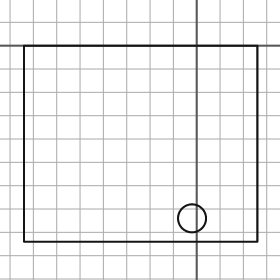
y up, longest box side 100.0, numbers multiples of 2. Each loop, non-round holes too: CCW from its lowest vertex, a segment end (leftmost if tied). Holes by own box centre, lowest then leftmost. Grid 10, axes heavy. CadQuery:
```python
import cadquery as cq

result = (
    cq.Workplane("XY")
    .moveTo(-74.0, -84.0)
    .lineTo(26.0, -84.0)
    .lineTo(26.0, 0.0)
    .lineTo(-74.0, 0.0)
    .close()
    .moveTo(-2.0, -74.0)
    .circle(6.0)
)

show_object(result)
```